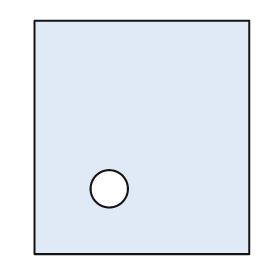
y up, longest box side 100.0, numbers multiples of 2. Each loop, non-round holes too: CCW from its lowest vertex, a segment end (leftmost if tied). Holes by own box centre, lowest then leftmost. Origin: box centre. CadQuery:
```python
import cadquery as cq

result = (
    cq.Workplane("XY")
    .moveTo(-46.0, -50.0)
    .lineTo(46.0, -50.0)
    .lineTo(46.0, 50.0)
    .lineTo(-46.0, 50.0)
    .close()
    .moveTo(-14.0, -22.0)
    .circle(8.0)
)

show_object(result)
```